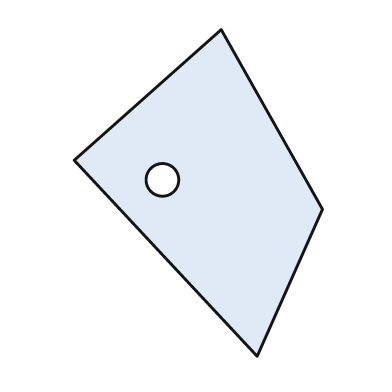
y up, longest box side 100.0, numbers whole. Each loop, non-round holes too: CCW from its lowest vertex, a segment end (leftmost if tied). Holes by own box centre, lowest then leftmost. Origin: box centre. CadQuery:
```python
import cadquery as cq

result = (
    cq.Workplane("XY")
    .moveTo(18.0, -50.0)
    .lineTo(38.0, -5.0)
    .lineTo(7.0, 50.0)
    .lineTo(-38.0, 10.0)
    .close()
    .moveTo(-11.0, 4.0)
    .circle(5.0)
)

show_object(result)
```